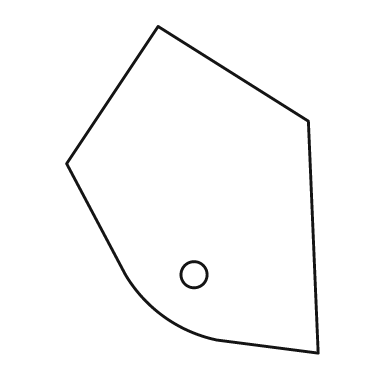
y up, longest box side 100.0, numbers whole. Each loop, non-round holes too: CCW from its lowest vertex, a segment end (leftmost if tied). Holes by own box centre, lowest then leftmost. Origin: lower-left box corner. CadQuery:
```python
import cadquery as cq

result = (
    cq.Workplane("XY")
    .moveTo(77.0, 0.0)
    .lineTo(74.0, 71.0)
    .lineTo(28.0, 100.0)
    .lineTo(0.0, 58.0)
    .lineTo(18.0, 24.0)
    .threePointArc((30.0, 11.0), (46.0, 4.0))
    .close()
    .moveTo(39.0, 24.0)
    .circle(4.0)
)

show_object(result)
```